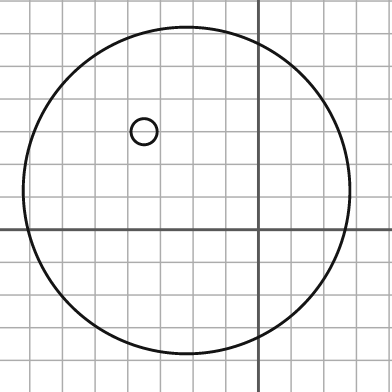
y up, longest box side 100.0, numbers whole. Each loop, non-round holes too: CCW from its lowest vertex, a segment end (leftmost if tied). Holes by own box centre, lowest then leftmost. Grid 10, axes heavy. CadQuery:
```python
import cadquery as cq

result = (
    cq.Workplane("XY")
    .moveTo(-22.0, 12.0)
    .circle(50.0)
    .moveTo(-35.0, 30.0)
    .circle(4.0)
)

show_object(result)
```